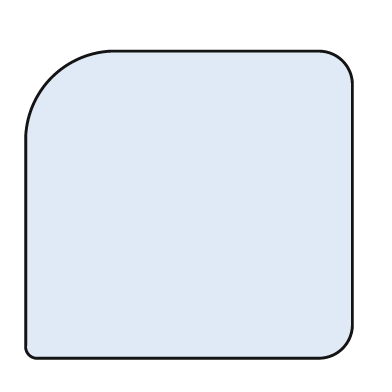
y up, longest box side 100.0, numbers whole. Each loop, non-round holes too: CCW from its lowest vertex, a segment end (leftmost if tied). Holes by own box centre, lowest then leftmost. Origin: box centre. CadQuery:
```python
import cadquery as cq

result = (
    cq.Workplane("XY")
    .moveTo(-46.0, -47.0)
    .lineTo(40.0, -47.0)
    .threePointArc((47.0, -44.0), (50.0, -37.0))
    .lineTo(50.0, 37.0)
    .threePointArc((47.0, 44.0), (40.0, 47.0))
    .lineTo(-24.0, 47.0)
    .threePointArc((-42.0, 39.0), (-50.0, 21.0))
    .lineTo(-50.0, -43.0)
    .threePointArc((-49.0, -46.0), (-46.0, -47.0))
    .close()
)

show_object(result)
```